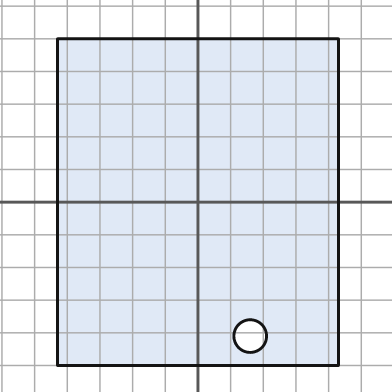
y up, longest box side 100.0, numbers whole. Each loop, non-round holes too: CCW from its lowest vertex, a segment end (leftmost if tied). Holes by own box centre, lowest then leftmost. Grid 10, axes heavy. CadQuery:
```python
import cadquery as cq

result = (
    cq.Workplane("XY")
    .moveTo(-43.0, -50.0)
    .lineTo(43.0, -50.0)
    .lineTo(43.0, 50.0)
    .lineTo(-43.0, 50.0)
    .close()
    .moveTo(16.0, -41.0)
    .circle(5.0)
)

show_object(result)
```